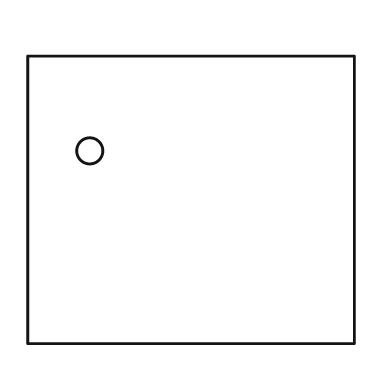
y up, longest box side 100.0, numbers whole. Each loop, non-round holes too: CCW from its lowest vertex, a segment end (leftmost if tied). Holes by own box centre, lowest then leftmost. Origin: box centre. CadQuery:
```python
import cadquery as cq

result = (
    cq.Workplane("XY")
    .moveTo(-50.0, -44.0)
    .lineTo(50.0, -44.0)
    .lineTo(50.0, 44.0)
    .lineTo(-50.0, 44.0)
    .close()
    .moveTo(-31.0, 15.0)
    .circle(4.0)
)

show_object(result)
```